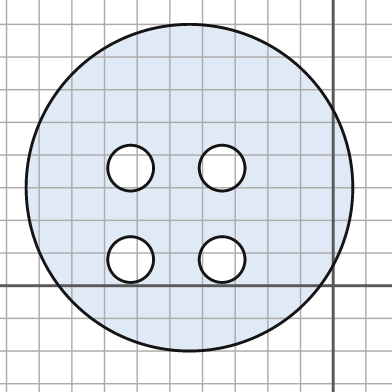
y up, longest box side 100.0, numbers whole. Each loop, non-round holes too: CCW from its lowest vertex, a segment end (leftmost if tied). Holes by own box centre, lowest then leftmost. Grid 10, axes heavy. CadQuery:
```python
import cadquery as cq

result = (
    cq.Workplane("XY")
    .moveTo(-44.0, 30.0)
    .circle(50.0)
    .moveTo(-62.0, 8.0)
    .circle(7.0)
    .moveTo(-34.0, 8.0)
    .circle(7.0)
    .moveTo(-62.0, 36.0)
    .circle(7.0)
    .moveTo(-34.0, 36.0)
    .circle(7.0)
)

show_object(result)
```